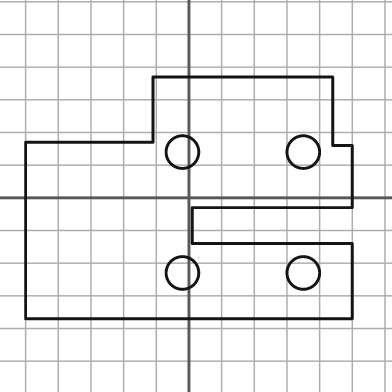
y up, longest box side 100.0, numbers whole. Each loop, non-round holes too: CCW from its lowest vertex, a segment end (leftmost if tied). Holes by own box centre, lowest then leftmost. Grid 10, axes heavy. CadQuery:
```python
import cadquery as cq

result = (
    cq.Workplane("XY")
    .moveTo(-50.0, -37.0)
    .lineTo(50.0, -37.0)
    .lineTo(50.0, -14.0)
    .lineTo(1.0, -14.0)
    .lineTo(1.0, -3.0)
    .lineTo(50.0, -3.0)
    .lineTo(50.0, 16.0)
    .lineTo(44.0, 16.0)
    .lineTo(44.0, 37.0)
    .lineTo(-11.0, 37.0)
    .lineTo(-11.0, 17.0)
    .lineTo(-50.0, 17.0)
    .close()
    .moveTo(-2.0, -23.0)
    .circle(5.0)
    .moveTo(35.0, -23.0)
    .circle(5.0)
    .moveTo(-2.0, 14.0)
    .circle(5.0)
    .moveTo(35.0, 14.0)
    .circle(5.0)
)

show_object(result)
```